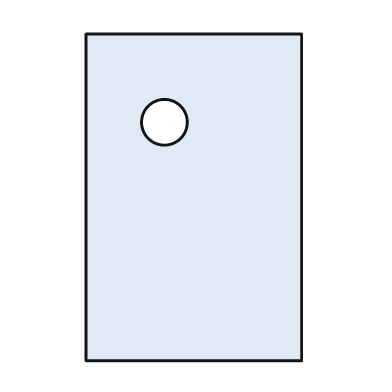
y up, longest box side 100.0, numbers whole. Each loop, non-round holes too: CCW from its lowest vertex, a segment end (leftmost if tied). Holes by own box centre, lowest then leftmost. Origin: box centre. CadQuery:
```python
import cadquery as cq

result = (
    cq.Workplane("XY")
    .moveTo(-33.0, -50.0)
    .lineTo(33.0, -50.0)
    .lineTo(33.0, 50.0)
    .lineTo(-33.0, 50.0)
    .close()
    .moveTo(-9.0, 23.0)
    .circle(7.0)
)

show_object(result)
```